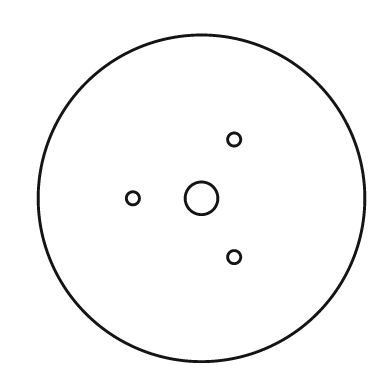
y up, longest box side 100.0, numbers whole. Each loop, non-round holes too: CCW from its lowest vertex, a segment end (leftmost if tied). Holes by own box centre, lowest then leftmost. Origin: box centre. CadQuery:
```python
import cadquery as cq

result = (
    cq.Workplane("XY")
    .moveTo(0.0, 0.0)
    .circle(50.0)
    .moveTo(10.0, -18.0)
    .circle(2.0)
    .moveTo(-21.0, 0.0)
    .circle(2.0)
    .moveTo(0.0, 0.0)
    .circle(5.0)
    .moveTo(10.0, 18.0)
    .circle(2.0)
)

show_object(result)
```